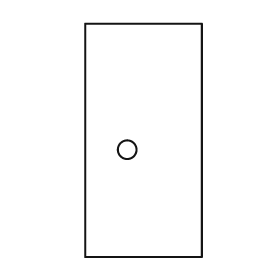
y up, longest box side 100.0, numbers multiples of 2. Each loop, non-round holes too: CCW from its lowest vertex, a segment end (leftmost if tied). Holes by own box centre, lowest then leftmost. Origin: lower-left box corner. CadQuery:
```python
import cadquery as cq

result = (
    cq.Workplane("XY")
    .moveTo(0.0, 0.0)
    .lineTo(50.0, 0.0)
    .lineTo(50.0, 100.0)
    .lineTo(0.0, 100.0)
    .close()
    .moveTo(18.0, 46.0)
    .circle(4.0)
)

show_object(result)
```